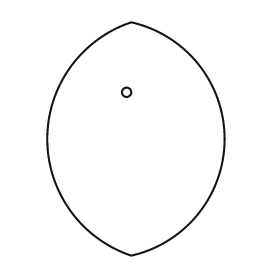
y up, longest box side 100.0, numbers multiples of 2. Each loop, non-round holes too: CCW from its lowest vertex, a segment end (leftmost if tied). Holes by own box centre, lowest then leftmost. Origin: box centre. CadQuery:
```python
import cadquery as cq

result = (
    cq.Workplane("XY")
    .moveTo(-2.0, -50.0)
    .threePointArc((38.0, 0.0), (-2.0, 50.0))
    .threePointArc((-38.0, 0.0), (-2.0, -50.0))
    .close()
    .moveTo(-4.0, 20.0)
    .circle(2.0)
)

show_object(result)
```